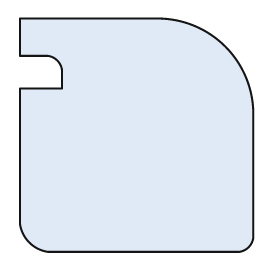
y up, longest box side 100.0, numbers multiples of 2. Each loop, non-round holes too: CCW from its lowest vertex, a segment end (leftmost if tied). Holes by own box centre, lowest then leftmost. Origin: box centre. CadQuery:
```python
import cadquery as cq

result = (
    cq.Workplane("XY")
    .moveTo(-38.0, -50.0)
    .lineTo(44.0, -50.0)
    .threePointArc((48.0, -48.0), (50.0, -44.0))
    .lineTo(50.0, 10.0)
    .threePointArc((38.0, 38.0), (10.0, 50.0))
    .lineTo(-50.0, 50.0)
    .lineTo(-50.0, 34.0)
    .lineTo(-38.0, 34.0)
    .threePointArc((-34.0, 32.0), (-32.0, 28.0))
    .lineTo(-32.0, 20.0)
    .lineTo(-50.0, 20.0)
    .lineTo(-50.0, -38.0)
    .threePointArc((-46.0, -46.0), (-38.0, -50.0))
    .close()
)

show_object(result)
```